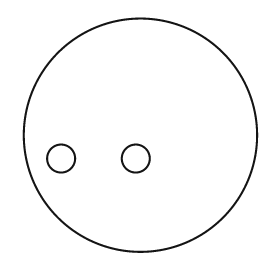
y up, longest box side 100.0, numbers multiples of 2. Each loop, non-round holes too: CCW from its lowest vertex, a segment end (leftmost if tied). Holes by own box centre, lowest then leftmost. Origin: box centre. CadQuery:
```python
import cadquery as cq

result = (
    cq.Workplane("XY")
    .moveTo(0.0, 0.0)
    .circle(50.0)
    .moveTo(-34.0, -10.0)
    .circle(6.0)
    .moveTo(-2.0, -10.0)
    .circle(6.0)
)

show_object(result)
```